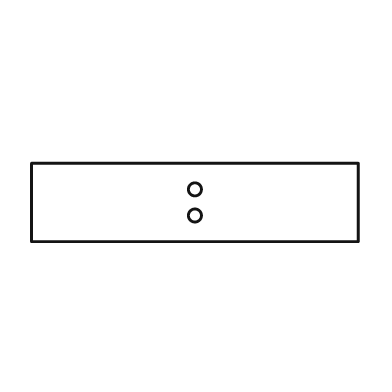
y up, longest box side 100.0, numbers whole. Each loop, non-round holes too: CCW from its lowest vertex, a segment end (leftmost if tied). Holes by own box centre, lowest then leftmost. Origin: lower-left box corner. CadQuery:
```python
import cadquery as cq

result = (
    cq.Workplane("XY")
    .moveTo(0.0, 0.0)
    .lineTo(100.0, 0.0)
    .lineTo(100.0, 24.0)
    .lineTo(0.0, 24.0)
    .close()
    .moveTo(50.0, 8.0)
    .circle(2.0)
    .moveTo(50.0, 16.0)
    .circle(2.0)
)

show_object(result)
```